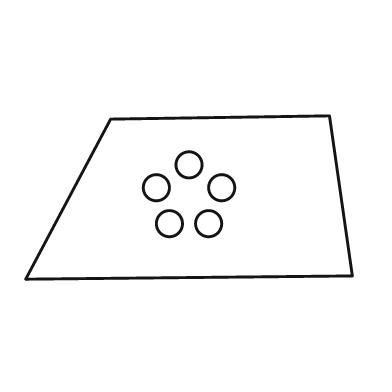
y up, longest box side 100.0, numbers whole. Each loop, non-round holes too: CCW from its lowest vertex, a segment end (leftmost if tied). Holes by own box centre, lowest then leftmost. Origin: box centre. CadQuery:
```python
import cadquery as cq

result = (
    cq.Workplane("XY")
    .moveTo(-50.0, -25.0)
    .lineTo(50.0, -24.0)
    .lineTo(43.0, 25.0)
    .lineTo(-24.0, 24.0)
    .close()
    .moveTo(-6.0, -8.0)
    .circle(4.0)
    .moveTo(6.0, -8.0)
    .circle(4.0)
    .moveTo(-10.0, 3.0)
    .circle(4.0)
    .moveTo(10.0, 3.0)
    .circle(4.0)
    .moveTo(0.0, 10.0)
    .circle(4.0)
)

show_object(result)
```